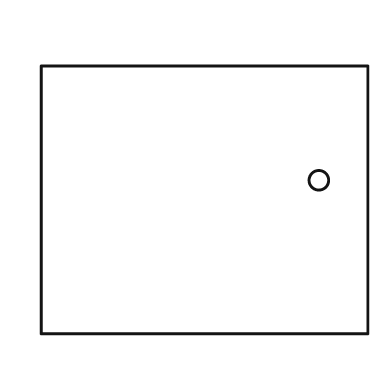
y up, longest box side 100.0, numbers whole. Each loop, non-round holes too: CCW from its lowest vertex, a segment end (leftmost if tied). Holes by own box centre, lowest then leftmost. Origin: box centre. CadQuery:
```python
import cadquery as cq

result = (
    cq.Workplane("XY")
    .moveTo(-50.0, -41.0)
    .lineTo(50.0, -41.0)
    .lineTo(50.0, 41.0)
    .lineTo(-50.0, 41.0)
    .close()
    .moveTo(35.0, 6.0)
    .circle(3.0)
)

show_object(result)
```